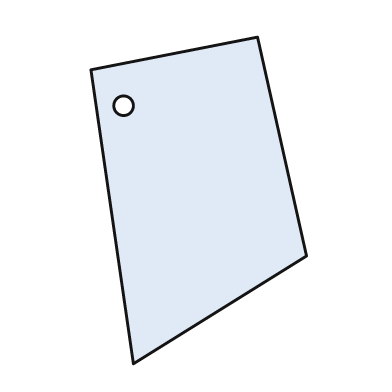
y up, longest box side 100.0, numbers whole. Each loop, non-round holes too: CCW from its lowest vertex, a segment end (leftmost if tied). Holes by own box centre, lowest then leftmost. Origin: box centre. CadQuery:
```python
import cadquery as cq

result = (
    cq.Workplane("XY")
    .moveTo(-20.0, -50.0)
    .lineTo(33.0, -17.0)
    .lineTo(18.0, 50.0)
    .lineTo(-33.0, 40.0)
    .close()
    .moveTo(-23.0, 29.0)
    .circle(3.0)
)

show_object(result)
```